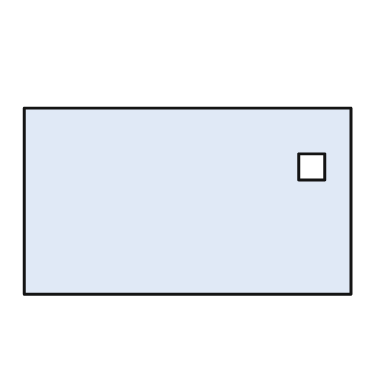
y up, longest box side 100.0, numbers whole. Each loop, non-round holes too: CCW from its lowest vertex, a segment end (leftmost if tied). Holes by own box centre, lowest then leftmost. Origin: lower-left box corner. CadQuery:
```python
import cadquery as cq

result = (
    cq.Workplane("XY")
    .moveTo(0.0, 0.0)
    .lineTo(100.0, 0.0)
    .lineTo(100.0, 57.0)
    .lineTo(0.0, 57.0)
    .close()
    .moveTo(84.0, 35.0)
    .lineTo(92.0, 35.0)
    .lineTo(92.0, 43.0)
    .lineTo(84.0, 43.0)
    .close()
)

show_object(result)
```